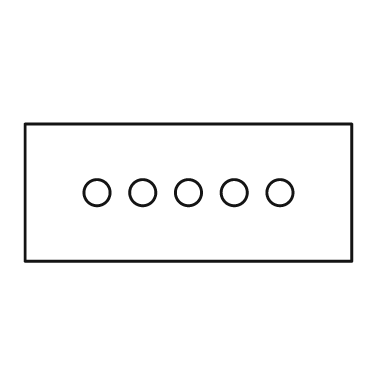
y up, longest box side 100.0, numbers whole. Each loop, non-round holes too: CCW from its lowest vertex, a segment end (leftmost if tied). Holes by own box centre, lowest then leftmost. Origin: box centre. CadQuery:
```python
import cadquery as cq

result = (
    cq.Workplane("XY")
    .moveTo(-50.0, -21.0)
    .lineTo(50.0, -21.0)
    .lineTo(50.0, 21.0)
    .lineTo(-50.0, 21.0)
    .close()
    .moveTo(-28.0, 0.0)
    .circle(4.0)
    .moveTo(-14.0, 0.0)
    .circle(4.0)
    .moveTo(0.0, 0.0)
    .circle(4.0)
    .moveTo(14.0, 0.0)
    .circle(4.0)
    .moveTo(28.0, 0.0)
    .circle(4.0)
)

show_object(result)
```